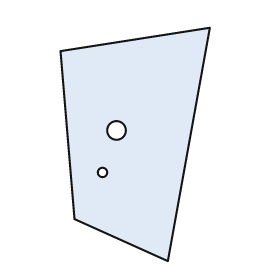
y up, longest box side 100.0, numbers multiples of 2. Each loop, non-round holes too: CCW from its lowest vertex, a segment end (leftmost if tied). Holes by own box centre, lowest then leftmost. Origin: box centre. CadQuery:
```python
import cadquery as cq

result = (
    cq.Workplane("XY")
    .moveTo(14.0, -50.0)
    .lineTo(32.0, 50.0)
    .lineTo(-32.0, 40.0)
    .lineTo(-26.0, -32.0)
    .close()
    .moveTo(-14.0, -12.0)
    .circle(2.0)
    .moveTo(-8.0, 6.0)
    .circle(4.0)
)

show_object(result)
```